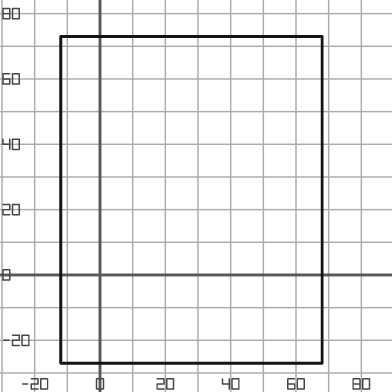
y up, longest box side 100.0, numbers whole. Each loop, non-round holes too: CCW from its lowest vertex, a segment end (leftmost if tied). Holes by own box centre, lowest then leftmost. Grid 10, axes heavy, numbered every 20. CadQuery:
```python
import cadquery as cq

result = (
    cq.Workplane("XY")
    .moveTo(-12.0, -27.0)
    .lineTo(68.0, -27.0)
    .lineTo(68.0, 73.0)
    .lineTo(-12.0, 73.0)
    .close()
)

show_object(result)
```